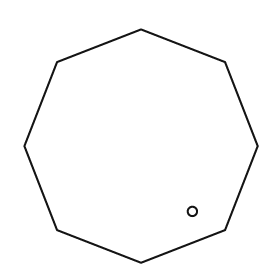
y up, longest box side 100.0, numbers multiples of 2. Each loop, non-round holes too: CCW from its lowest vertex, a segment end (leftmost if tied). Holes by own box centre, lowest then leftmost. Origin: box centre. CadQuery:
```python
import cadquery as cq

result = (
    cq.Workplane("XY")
    .moveTo(0.0, -50.0)
    .lineTo(36.0, -36.0)
    .lineTo(50.0, 0.0)
    .lineTo(36.0, 36.0)
    .lineTo(0.0, 50.0)
    .lineTo(-36.0, 36.0)
    .lineTo(-50.0, 0.0)
    .lineTo(-36.0, -36.0)
    .close()
    .moveTo(22.0, -28.0)
    .circle(2.0)
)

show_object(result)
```